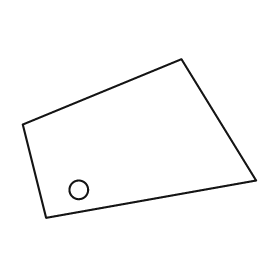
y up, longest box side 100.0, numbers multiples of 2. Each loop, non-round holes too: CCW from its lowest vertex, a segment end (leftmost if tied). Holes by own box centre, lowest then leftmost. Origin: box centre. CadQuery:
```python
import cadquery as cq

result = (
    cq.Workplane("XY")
    .moveTo(-40.0, -34.0)
    .lineTo(50.0, -18.0)
    .lineTo(18.0, 34.0)
    .lineTo(-50.0, 6.0)
    .close()
    .moveTo(-26.0, -22.0)
    .circle(4.0)
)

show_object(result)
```